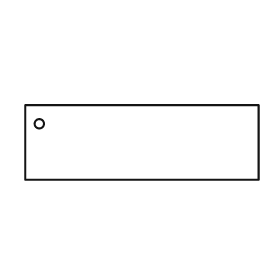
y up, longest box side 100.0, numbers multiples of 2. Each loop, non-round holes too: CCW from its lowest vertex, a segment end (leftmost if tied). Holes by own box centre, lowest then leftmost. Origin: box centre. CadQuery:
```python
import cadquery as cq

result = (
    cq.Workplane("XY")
    .moveTo(-50.0, -16.0)
    .lineTo(50.0, -16.0)
    .lineTo(50.0, 16.0)
    .lineTo(-50.0, 16.0)
    .close()
    .moveTo(-44.0, 8.0)
    .circle(2.0)
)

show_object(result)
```